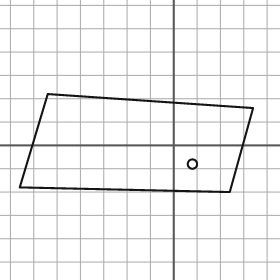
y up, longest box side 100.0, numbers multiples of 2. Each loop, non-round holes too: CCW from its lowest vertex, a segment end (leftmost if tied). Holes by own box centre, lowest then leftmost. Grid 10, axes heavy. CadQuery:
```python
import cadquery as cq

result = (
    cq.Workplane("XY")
    .moveTo(24.0, -20.0)
    .lineTo(34.0, 16.0)
    .lineTo(-54.0, 22.0)
    .lineTo(-66.0, -18.0)
    .close()
    .moveTo(8.0, -8.0)
    .circle(2.0)
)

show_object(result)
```